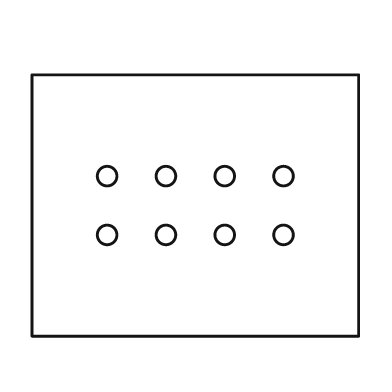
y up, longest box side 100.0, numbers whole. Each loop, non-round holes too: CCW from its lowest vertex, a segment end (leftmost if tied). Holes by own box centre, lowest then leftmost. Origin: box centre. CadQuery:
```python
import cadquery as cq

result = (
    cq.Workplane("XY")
    .moveTo(-50.0, -40.0)
    .lineTo(50.0, -40.0)
    .lineTo(50.0, 40.0)
    .lineTo(-50.0, 40.0)
    .close()
    .moveTo(-27.0, -9.0)
    .circle(3.0)
    .moveTo(-9.0, -9.0)
    .circle(3.0)
    .moveTo(9.0, -9.0)
    .circle(3.0)
    .moveTo(27.0, -9.0)
    .circle(3.0)
    .moveTo(-27.0, 9.0)
    .circle(3.0)
    .moveTo(-9.0, 9.0)
    .circle(3.0)
    .moveTo(9.0, 9.0)
    .circle(3.0)
    .moveTo(27.0, 9.0)
    .circle(3.0)
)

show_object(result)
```